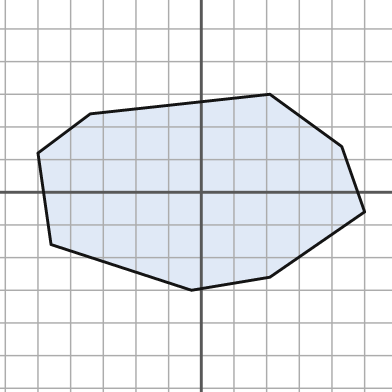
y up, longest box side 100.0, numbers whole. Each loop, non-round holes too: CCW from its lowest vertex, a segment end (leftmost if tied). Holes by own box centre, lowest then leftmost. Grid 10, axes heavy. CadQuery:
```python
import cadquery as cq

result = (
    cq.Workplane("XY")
    .moveTo(-3.0, -30.0)
    .lineTo(21.0, -26.0)
    .lineTo(50.0, -6.0)
    .lineTo(43.0, 14.0)
    .lineTo(21.0, 30.0)
    .lineTo(-34.0, 24.0)
    .lineTo(-50.0, 12.0)
    .lineTo(-46.0, -16.0)
    .close()
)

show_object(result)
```